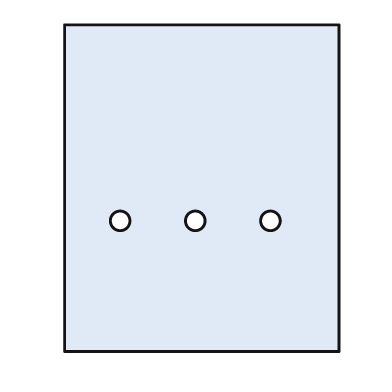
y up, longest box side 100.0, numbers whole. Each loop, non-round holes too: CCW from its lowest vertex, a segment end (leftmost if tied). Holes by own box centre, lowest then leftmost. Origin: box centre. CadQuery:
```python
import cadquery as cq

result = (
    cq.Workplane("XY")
    .moveTo(-42.0, -50.0)
    .lineTo(42.0, -50.0)
    .lineTo(42.0, 50.0)
    .lineTo(-42.0, 50.0)
    .close()
    .moveTo(-25.0, -10.0)
    .circle(3.0)
    .moveTo(-2.0, -10.0)
    .circle(3.0)
    .moveTo(21.0, -10.0)
    .circle(3.0)
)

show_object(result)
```